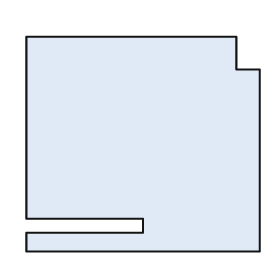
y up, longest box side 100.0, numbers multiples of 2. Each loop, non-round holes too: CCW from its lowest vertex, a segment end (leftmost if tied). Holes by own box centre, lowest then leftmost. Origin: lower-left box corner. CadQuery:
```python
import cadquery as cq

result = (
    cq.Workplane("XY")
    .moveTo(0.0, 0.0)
    .lineTo(100.0, 0.0)
    .lineTo(100.0, 78.0)
    .lineTo(90.0, 78.0)
    .lineTo(90.0, 92.0)
    .lineTo(0.0, 92.0)
    .lineTo(0.0, 14.0)
    .lineTo(50.0, 14.0)
    .lineTo(50.0, 8.0)
    .lineTo(0.0, 8.0)
    .close()
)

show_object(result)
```